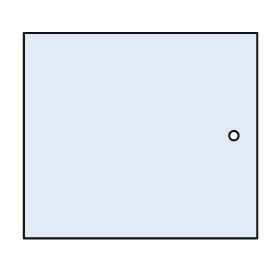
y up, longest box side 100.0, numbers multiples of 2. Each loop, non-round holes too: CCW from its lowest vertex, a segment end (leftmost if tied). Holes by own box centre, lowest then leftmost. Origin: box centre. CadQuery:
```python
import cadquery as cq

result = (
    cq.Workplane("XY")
    .moveTo(-50.0, -44.0)
    .lineTo(50.0, -44.0)
    .lineTo(50.0, 44.0)
    .lineTo(-50.0, 44.0)
    .close()
    .moveTo(40.0, 0.0)
    .circle(2.0)
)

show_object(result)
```